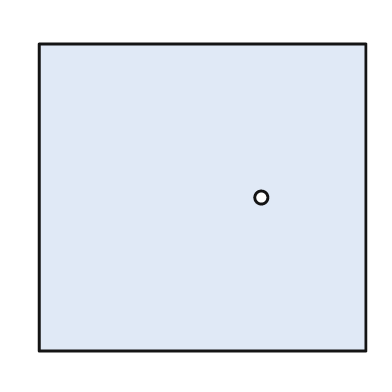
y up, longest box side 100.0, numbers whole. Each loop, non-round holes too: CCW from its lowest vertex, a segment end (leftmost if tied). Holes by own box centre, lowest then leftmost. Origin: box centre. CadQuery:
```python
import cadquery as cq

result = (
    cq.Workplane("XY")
    .moveTo(-50.0, -47.0)
    .lineTo(50.0, -47.0)
    .lineTo(50.0, 47.0)
    .lineTo(-50.0, 47.0)
    .close()
    .moveTo(18.0, 0.0)
    .circle(2.0)
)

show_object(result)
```